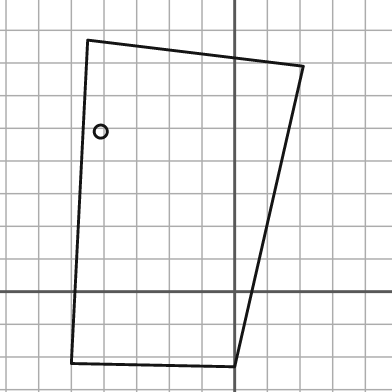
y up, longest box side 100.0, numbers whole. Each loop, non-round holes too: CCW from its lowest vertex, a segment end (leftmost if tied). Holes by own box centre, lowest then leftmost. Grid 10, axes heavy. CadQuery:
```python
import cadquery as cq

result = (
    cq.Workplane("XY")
    .moveTo(0.0, -23.0)
    .lineTo(21.0, 69.0)
    .lineTo(-45.0, 77.0)
    .lineTo(-50.0, -22.0)
    .close()
    .moveTo(-41.0, 49.0)
    .circle(2.0)
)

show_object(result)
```